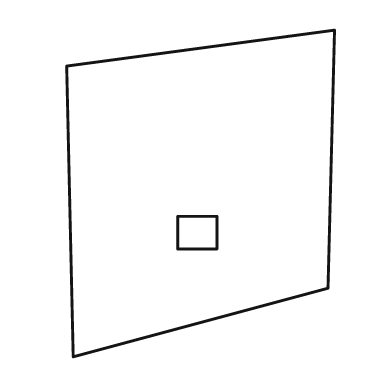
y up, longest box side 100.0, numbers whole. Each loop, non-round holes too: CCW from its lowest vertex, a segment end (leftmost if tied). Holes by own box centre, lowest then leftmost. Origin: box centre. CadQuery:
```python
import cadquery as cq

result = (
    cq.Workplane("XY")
    .moveTo(-39.0, -50.0)
    .lineTo(39.0, -29.0)
    .lineTo(41.0, 50.0)
    .lineTo(-41.0, 39.0)
    .close()
    .moveTo(-7.0, -17.0)
    .lineTo(5.0, -17.0)
    .lineTo(5.0, -7.0)
    .lineTo(-7.0, -7.0)
    .close()
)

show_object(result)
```